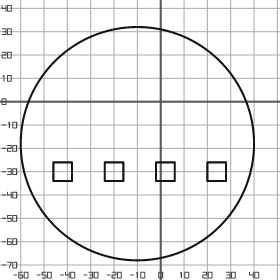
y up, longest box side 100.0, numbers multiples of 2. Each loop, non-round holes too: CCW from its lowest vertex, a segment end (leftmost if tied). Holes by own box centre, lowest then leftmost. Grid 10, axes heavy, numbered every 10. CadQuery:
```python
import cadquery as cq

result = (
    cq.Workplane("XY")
    .moveTo(-10.0, -18.0)
    .circle(50.0)
    .moveTo(-46.0, -34.0)
    .lineTo(-38.0, -34.0)
    .lineTo(-38.0, -26.0)
    .lineTo(-46.0, -26.0)
    .close()
    .moveTo(-24.0, -34.0)
    .lineTo(-16.0, -34.0)
    .lineTo(-16.0, -26.0)
    .lineTo(-24.0, -26.0)
    .close()
    .moveTo(-2.0, -34.0)
    .lineTo(6.0, -34.0)
    .lineTo(6.0, -26.0)
    .lineTo(-2.0, -26.0)
    .close()
    .moveTo(20.0, -34.0)
    .lineTo(28.0, -34.0)
    .lineTo(28.0, -26.0)
    .lineTo(20.0, -26.0)
    .close()
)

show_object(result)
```